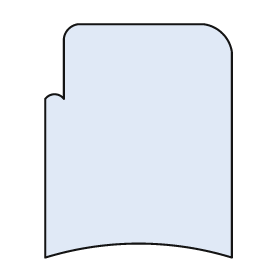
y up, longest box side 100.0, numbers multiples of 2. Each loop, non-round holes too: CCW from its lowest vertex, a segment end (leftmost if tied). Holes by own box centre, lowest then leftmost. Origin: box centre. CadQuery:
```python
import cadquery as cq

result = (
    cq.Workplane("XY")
    .moveTo(-40.0, -50.0)
    .threePointArc((0.0, -44.0), (40.0, -50.0))
    .lineTo(40.0, 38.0)
    .threePointArc((36.0, 46.0), (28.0, 50.0))
    .lineTo(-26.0, 50.0)
    .threePointArc((-30.0, 48.0), (-32.0, 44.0))
    .lineTo(-32.0, 18.0)
    .threePointArc((-36.0, 20.0), (-40.0, 18.0))
    .close()
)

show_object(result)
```